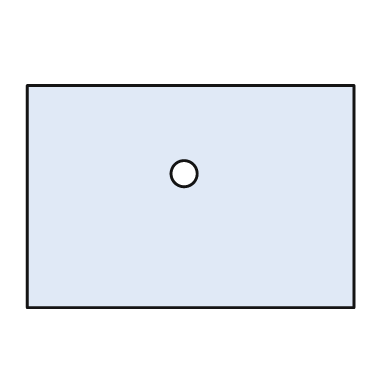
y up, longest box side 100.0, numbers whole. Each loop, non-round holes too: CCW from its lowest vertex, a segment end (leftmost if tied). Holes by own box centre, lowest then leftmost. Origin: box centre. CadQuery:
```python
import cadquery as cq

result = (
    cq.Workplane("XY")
    .moveTo(-50.0, -34.0)
    .lineTo(50.0, -34.0)
    .lineTo(50.0, 34.0)
    .lineTo(-50.0, 34.0)
    .close()
    .moveTo(-2.0, 7.0)
    .circle(4.0)
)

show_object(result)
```